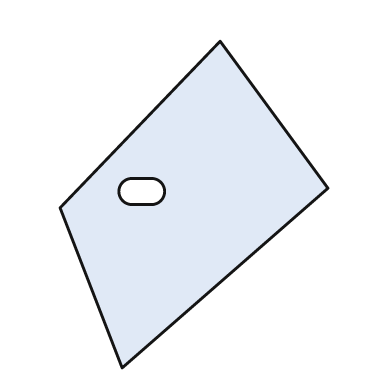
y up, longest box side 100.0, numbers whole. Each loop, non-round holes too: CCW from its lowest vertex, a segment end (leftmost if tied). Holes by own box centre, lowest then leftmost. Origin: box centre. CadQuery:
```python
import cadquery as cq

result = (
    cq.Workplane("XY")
    .moveTo(-22.0, -50.0)
    .lineTo(41.0, 5.0)
    .lineTo(8.0, 50.0)
    .lineTo(-41.0, -1.0)
    .close()
    .moveTo(-19.0, 0.0)
    .lineTo(-13.0, 0.0)
    .threePointArc((-9.0, 4.0), (-13.0, 8.0))
    .lineTo(-19.0, 8.0)
    .threePointArc((-23.0, 4.0), (-19.0, 0.0))
    .close()
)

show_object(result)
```